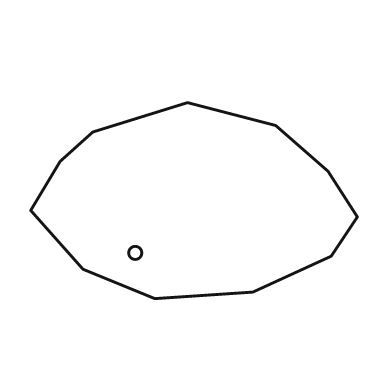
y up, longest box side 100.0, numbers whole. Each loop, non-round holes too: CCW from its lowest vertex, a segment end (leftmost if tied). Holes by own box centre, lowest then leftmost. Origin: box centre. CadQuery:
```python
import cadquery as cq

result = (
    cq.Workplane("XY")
    .moveTo(-12.0, -30.0)
    .lineTo(18.0, -28.0)
    .lineTo(42.0, -17.0)
    .lineTo(50.0, -5.0)
    .lineTo(41.0, 9.0)
    .lineTo(25.0, 23.0)
    .lineTo(-2.0, 30.0)
    .lineTo(-31.0, 21.0)
    .lineTo(-41.0, 12.0)
    .lineTo(-50.0, -3.0)
    .lineTo(-34.0, -21.0)
    .close()
    .moveTo(-18.0, -16.0)
    .circle(2.0)
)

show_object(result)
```